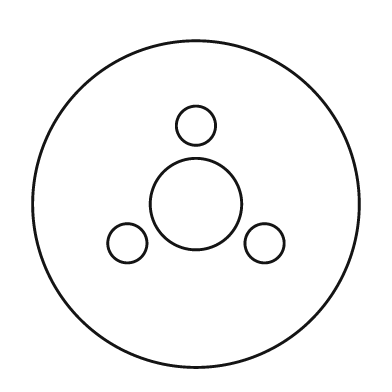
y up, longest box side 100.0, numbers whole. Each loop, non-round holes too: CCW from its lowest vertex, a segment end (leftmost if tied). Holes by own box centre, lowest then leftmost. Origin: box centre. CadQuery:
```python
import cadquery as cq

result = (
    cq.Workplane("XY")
    .moveTo(0.0, 0.0)
    .circle(50.0)
    .moveTo(-21.0, -12.0)
    .circle(6.0)
    .moveTo(21.0, -12.0)
    .circle(6.0)
    .moveTo(0.0, 0.0)
    .circle(14.0)
    .moveTo(0.0, 24.0)
    .circle(6.0)
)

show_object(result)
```